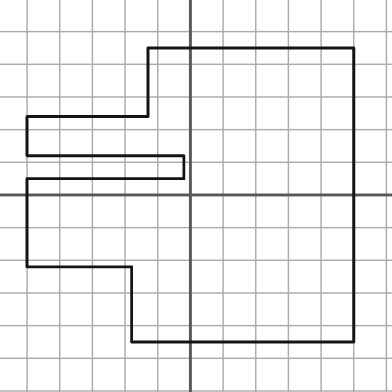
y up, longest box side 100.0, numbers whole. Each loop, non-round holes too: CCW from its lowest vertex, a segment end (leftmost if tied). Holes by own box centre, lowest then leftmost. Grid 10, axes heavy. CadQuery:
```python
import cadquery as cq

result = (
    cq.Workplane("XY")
    .moveTo(-18.0, -45.0)
    .lineTo(50.0, -45.0)
    .lineTo(50.0, 45.0)
    .lineTo(-13.0, 45.0)
    .lineTo(-13.0, 24.0)
    .lineTo(-50.0, 24.0)
    .lineTo(-50.0, 12.0)
    .lineTo(-2.0, 12.0)
    .lineTo(-2.0, 5.0)
    .lineTo(-50.0, 5.0)
    .lineTo(-50.0, -22.0)
    .lineTo(-18.0, -22.0)
    .close()
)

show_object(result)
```